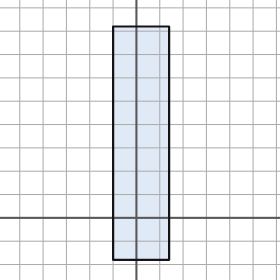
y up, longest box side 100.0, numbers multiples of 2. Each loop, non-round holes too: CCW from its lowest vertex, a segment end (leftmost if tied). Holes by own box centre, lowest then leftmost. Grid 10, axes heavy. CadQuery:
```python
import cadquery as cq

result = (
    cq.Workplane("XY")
    .moveTo(-10.0, -18.0)
    .lineTo(14.0, -18.0)
    .lineTo(14.0, 82.0)
    .lineTo(-10.0, 82.0)
    .close()
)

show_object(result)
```